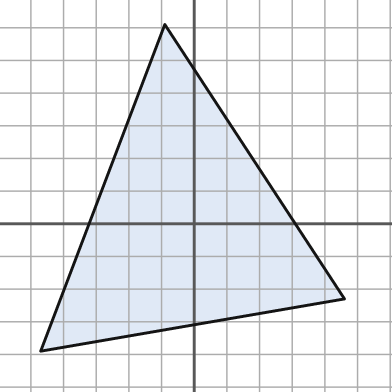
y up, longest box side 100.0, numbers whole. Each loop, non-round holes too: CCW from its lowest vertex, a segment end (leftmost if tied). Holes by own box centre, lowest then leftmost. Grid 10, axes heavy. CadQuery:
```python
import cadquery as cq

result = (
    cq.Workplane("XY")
    .moveTo(-47.0, -39.0)
    .lineTo(46.0, -23.0)
    .lineTo(-9.0, 61.0)
    .close()
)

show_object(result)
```